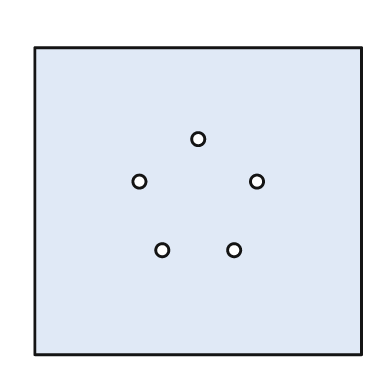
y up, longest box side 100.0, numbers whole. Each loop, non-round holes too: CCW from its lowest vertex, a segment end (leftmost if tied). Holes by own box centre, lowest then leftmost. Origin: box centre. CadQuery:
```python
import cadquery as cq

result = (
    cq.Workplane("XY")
    .moveTo(-50.0, -47.0)
    .lineTo(50.0, -47.0)
    .lineTo(50.0, 47.0)
    .lineTo(-50.0, 47.0)
    .close()
    .moveTo(-11.0, -15.0)
    .circle(2.0)
    .moveTo(11.0, -15.0)
    .circle(2.0)
    .moveTo(-18.0, 6.0)
    .circle(2.0)
    .moveTo(18.0, 6.0)
    .circle(2.0)
    .moveTo(0.0, 19.0)
    .circle(2.0)
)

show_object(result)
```